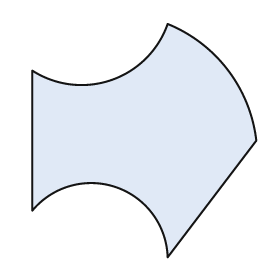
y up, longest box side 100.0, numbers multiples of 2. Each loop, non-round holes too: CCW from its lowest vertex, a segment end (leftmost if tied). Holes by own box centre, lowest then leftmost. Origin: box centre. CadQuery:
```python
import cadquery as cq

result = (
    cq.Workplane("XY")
    .moveTo(10.0, -50.0)
    .lineTo(48.0, 0.0)
    .threePointArc((36.0, 30.0), (10.0, 50.0))
    .threePointArc((-14.0, 26.0), (-48.0, 30.0))
    .lineTo(-48.0, -30.0)
    .threePointArc((-12.0, -20.0), (10.0, -50.0))
    .close()
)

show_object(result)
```